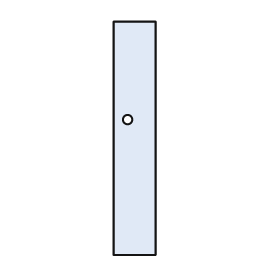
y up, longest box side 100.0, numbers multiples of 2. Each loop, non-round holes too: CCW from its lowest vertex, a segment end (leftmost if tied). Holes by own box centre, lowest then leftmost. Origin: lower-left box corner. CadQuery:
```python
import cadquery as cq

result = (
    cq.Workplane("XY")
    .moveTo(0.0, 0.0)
    .lineTo(18.0, 0.0)
    .lineTo(18.0, 100.0)
    .lineTo(0.0, 100.0)
    .close()
    .moveTo(6.0, 58.0)
    .circle(2.0)
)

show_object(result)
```